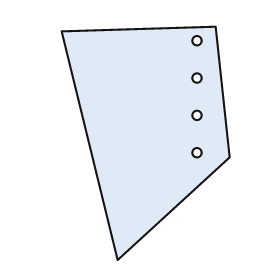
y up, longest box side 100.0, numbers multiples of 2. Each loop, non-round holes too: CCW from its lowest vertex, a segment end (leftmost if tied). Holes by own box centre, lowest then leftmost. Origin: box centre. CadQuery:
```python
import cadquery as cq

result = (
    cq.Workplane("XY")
    .moveTo(-12.0, -50.0)
    .lineTo(36.0, -6.0)
    .lineTo(30.0, 50.0)
    .lineTo(-36.0, 48.0)
    .close()
    .moveTo(22.0, -4.0)
    .circle(2.0)
    .moveTo(22.0, 12.0)
    .circle(2.0)
    .moveTo(22.0, 28.0)
    .circle(2.0)
    .moveTo(22.0, 44.0)
    .circle(2.0)
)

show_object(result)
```